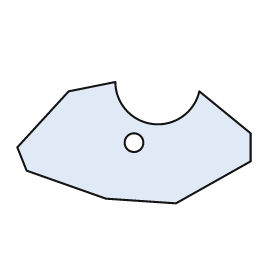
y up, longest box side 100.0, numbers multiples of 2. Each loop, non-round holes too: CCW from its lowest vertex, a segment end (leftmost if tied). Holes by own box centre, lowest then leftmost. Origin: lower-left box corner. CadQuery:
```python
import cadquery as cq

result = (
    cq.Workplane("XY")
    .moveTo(68.0, 0.0)
    .lineTo(100.0, 18.0)
    .lineTo(100.0, 30.0)
    .lineTo(78.0, 48.0)
    .threePointArc((58.0, 34.0), (42.0, 52.0))
    .lineTo(22.0, 48.0)
    .lineTo(0.0, 24.0)
    .lineTo(4.0, 14.0)
    .lineTo(38.0, 2.0)
    .close()
    .moveTo(50.0, 26.0)
    .circle(4.0)
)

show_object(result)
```